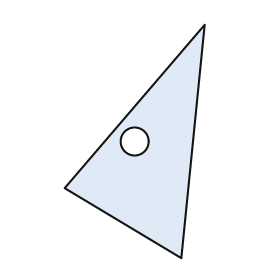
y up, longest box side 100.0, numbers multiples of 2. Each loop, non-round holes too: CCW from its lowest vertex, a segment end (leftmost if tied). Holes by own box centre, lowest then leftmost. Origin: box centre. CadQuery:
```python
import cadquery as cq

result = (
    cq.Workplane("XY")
    .moveTo(20.0, -50.0)
    .lineTo(30.0, 50.0)
    .lineTo(-30.0, -20.0)
    .close()
    .moveTo(0.0, 0.0)
    .circle(6.0)
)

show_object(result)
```